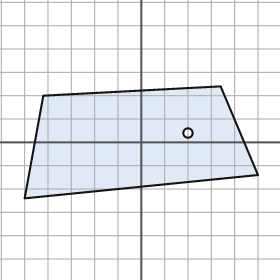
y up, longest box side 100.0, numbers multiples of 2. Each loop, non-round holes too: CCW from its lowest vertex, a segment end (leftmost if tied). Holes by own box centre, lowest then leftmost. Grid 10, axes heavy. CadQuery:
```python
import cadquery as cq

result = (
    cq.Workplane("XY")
    .moveTo(-50.0, -24.0)
    .lineTo(50.0, -14.0)
    .lineTo(34.0, 24.0)
    .lineTo(-42.0, 20.0)
    .close()
    .moveTo(20.0, 4.0)
    .circle(2.0)
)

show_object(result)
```